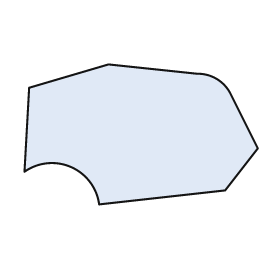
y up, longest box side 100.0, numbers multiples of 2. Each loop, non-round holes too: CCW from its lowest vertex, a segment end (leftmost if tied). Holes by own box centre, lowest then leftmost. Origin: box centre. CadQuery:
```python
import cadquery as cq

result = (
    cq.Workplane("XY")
    .moveTo(-18.0, -30.0)
    .lineTo(36.0, -24.0)
    .lineTo(50.0, -6.0)
    .lineTo(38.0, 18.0)
    .threePointArc((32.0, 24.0), (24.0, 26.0))
    .lineTo(-14.0, 30.0)
    .lineTo(-48.0, 20.0)
    .lineTo(-50.0, -16.0)
    .threePointArc((-30.0, -14.0), (-18.0, -30.0))
    .close()
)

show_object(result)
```